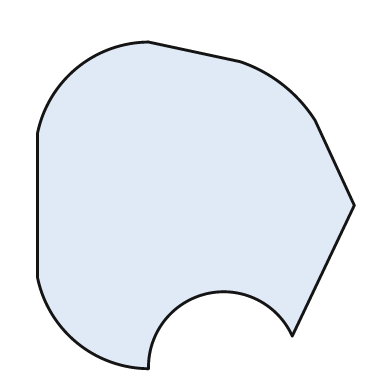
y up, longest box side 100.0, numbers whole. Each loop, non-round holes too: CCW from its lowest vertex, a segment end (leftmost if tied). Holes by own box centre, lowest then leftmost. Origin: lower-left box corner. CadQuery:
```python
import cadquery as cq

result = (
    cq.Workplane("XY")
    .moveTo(34.0, 0.0)
    .threePointArc((52.0, 23.0), (78.0, 10.0))
    .lineTo(97.0, 50.0)
    .lineTo(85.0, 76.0)
    .threePointArc((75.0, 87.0), (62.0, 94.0))
    .lineTo(34.0, 100.0)
    .threePointArc((12.0, 92.0), (0.0, 72.0))
    .lineTo(0.0, 28.0)
    .threePointArc((12.0, 8.0), (34.0, 0.0))
    .close()
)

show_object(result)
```